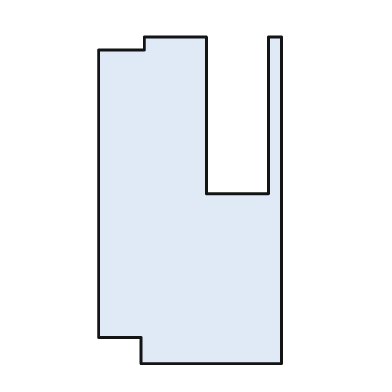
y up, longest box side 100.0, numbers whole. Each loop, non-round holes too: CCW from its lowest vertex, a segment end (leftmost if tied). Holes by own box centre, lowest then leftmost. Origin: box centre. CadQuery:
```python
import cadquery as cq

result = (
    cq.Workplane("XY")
    .moveTo(-15.0, -50.0)
    .lineTo(28.0, -50.0)
    .lineTo(28.0, 50.0)
    .lineTo(24.0, 50.0)
    .lineTo(24.0, 2.0)
    .lineTo(5.0, 2.0)
    .lineTo(5.0, 50.0)
    .lineTo(-14.0, 50.0)
    .lineTo(-14.0, 46.0)
    .lineTo(-28.0, 46.0)
    .lineTo(-28.0, -42.0)
    .lineTo(-15.0, -42.0)
    .close()
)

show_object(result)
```